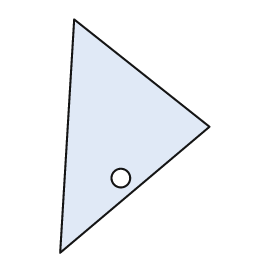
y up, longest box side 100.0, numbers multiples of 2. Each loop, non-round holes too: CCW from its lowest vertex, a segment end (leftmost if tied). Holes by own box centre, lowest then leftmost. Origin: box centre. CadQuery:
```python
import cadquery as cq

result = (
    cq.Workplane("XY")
    .moveTo(-32.0, -50.0)
    .lineTo(32.0, 4.0)
    .lineTo(-26.0, 50.0)
    .close()
    .moveTo(-6.0, -18.0)
    .circle(4.0)
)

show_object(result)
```